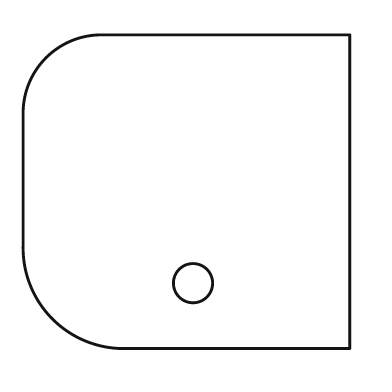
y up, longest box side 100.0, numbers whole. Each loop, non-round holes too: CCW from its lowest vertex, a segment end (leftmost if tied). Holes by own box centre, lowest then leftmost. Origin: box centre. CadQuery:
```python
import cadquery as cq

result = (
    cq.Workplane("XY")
    .moveTo(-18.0, -48.0)
    .lineTo(50.0, -48.0)
    .lineTo(50.0, 48.0)
    .lineTo(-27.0, 48.0)
    .threePointArc((-43.0, 41.0), (-50.0, 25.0))
    .lineTo(-50.0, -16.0)
    .threePointArc((-41.0, -39.0), (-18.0, -48.0))
    .close()
    .moveTo(2.0, -28.0)
    .circle(6.0)
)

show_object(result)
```